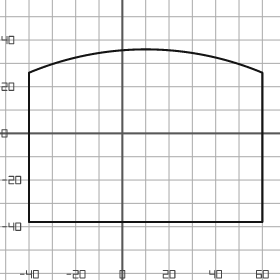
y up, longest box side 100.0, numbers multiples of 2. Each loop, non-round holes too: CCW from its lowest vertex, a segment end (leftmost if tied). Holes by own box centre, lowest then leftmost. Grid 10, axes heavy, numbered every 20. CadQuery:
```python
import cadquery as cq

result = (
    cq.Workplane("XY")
    .moveTo(-40.0, -38.0)
    .lineTo(60.0, -38.0)
    .lineTo(60.0, 26.0)
    .threePointArc((10.0, 36.0), (-40.0, 26.0))
    .close()
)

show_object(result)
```